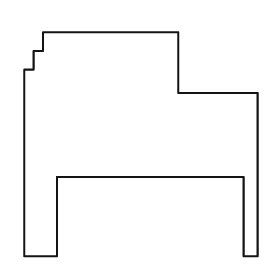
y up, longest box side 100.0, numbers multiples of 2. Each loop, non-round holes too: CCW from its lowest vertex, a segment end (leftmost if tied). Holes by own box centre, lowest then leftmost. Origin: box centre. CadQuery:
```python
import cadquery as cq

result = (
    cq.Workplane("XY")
    .moveTo(-50.0, -48.0)
    .lineTo(-36.0, -48.0)
    .lineTo(-36.0, -14.0)
    .lineTo(44.0, -14.0)
    .lineTo(44.0, -48.0)
    .lineTo(50.0, -48.0)
    .lineTo(50.0, 22.0)
    .lineTo(16.0, 22.0)
    .lineTo(16.0, 48.0)
    .lineTo(-42.0, 48.0)
    .lineTo(-42.0, 40.0)
    .lineTo(-46.0, 40.0)
    .lineTo(-46.0, 32.0)
    .lineTo(-50.0, 32.0)
    .close()
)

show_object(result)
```